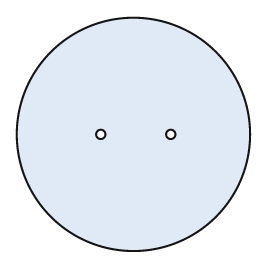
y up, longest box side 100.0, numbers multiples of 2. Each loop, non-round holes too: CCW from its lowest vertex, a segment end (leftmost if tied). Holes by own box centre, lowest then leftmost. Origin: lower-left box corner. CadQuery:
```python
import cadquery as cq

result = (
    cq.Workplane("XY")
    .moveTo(50.0, 50.0)
    .circle(50.0)
    .moveTo(36.0, 50.0)
    .circle(2.0)
    .moveTo(66.0, 50.0)
    .circle(2.0)
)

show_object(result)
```